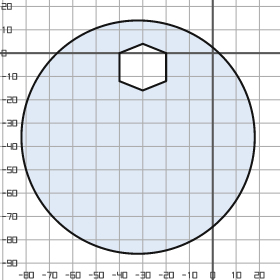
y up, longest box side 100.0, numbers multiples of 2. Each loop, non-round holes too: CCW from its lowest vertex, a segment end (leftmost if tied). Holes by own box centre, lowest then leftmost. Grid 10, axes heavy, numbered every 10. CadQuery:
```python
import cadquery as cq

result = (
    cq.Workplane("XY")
    .moveTo(-32.0, -36.0)
    .circle(50.0)
    .moveTo(-30.0, -16.0)
    .lineTo(-20.0, -12.0)
    .lineTo(-20.0, 0.0)
    .lineTo(-30.0, 4.0)
    .lineTo(-40.0, 0.0)
    .lineTo(-40.0, -12.0)
    .close()
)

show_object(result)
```